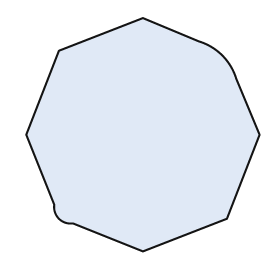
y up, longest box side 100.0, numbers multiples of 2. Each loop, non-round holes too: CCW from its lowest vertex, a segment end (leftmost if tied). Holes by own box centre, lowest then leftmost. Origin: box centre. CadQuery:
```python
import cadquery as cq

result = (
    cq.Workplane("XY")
    .moveTo(0.0, -50.0)
    .lineTo(36.0, -36.0)
    .lineTo(50.0, 0.0)
    .lineTo(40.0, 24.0)
    .threePointArc((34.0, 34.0), (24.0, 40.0))
    .lineTo(0.0, 50.0)
    .lineTo(-36.0, 36.0)
    .lineTo(-50.0, 0.0)
    .lineTo(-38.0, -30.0)
    .threePointArc((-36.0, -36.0), (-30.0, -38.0))
    .close()
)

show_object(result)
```